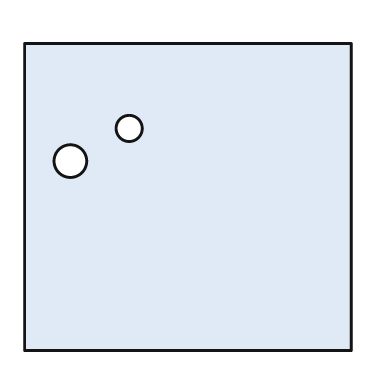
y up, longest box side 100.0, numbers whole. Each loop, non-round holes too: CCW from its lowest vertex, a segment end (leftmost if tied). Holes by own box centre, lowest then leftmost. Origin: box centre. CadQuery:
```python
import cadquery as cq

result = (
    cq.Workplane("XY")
    .moveTo(-50.0, -47.0)
    .lineTo(50.0, -47.0)
    .lineTo(50.0, 47.0)
    .lineTo(-50.0, 47.0)
    .close()
    .moveTo(-36.0, 11.0)
    .circle(5.0)
    .moveTo(-18.0, 21.0)
    .circle(4.0)
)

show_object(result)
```